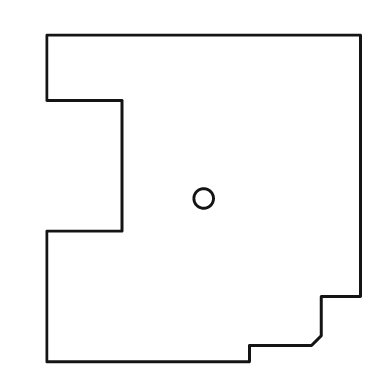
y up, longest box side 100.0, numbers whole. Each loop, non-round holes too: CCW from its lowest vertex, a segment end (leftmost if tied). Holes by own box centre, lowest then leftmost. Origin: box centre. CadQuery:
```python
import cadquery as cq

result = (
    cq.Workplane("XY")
    .moveTo(-48.0, -50.0)
    .lineTo(14.0, -50.0)
    .lineTo(14.0, -45.0)
    .lineTo(33.0, -45.0)
    .lineTo(36.0, -42.0)
    .lineTo(36.0, -30.0)
    .lineTo(48.0, -30.0)
    .lineTo(48.0, 50.0)
    .lineTo(-48.0, 50.0)
    .lineTo(-48.0, 30.0)
    .lineTo(-25.0, 30.0)
    .lineTo(-25.0, -10.0)
    .lineTo(-48.0, -10.0)
    .close()
    .moveTo(0.0, 0.0)
    .circle(3.0)
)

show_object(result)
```